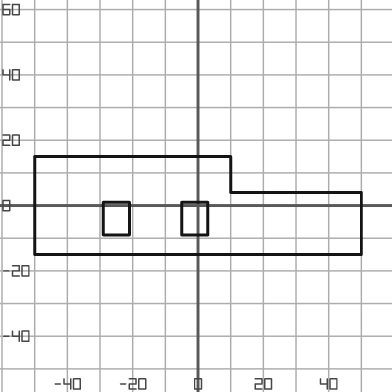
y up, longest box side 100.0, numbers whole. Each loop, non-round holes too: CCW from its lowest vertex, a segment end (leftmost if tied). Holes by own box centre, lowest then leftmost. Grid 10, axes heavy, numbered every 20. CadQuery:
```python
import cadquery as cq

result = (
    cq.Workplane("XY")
    .moveTo(-50.0, -15.0)
    .lineTo(50.0, -15.0)
    .lineTo(50.0, 4.0)
    .lineTo(10.0, 4.0)
    .lineTo(10.0, 15.0)
    .lineTo(-50.0, 15.0)
    .close()
    .moveTo(-29.0, -9.0)
    .lineTo(-21.0, -9.0)
    .lineTo(-21.0, 1.0)
    .lineTo(-29.0, 1.0)
    .close()
    .moveTo(-5.0, -9.0)
    .lineTo(3.0, -9.0)
    .lineTo(3.0, 1.0)
    .lineTo(-5.0, 1.0)
    .close()
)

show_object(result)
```